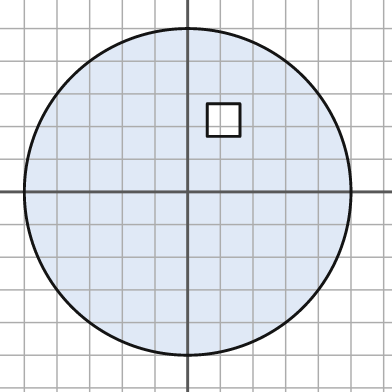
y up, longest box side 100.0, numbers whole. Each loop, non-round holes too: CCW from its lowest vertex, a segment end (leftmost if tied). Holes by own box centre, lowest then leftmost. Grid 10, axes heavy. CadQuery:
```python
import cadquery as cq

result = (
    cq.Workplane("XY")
    .moveTo(0.0, 0.0)
    .circle(50.0)
    .moveTo(6.0, 17.0)
    .lineTo(16.0, 17.0)
    .lineTo(16.0, 27.0)
    .lineTo(6.0, 27.0)
    .close()
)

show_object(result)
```